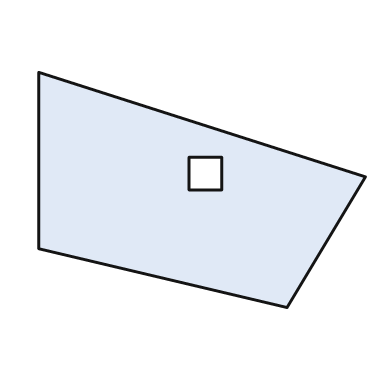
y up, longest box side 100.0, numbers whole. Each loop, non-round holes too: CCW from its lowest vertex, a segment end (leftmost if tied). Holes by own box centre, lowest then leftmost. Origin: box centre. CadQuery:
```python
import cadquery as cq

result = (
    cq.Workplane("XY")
    .moveTo(26.0, -36.0)
    .lineTo(50.0, 4.0)
    .lineTo(-50.0, 36.0)
    .lineTo(-50.0, -18.0)
    .close()
    .moveTo(-4.0, 0.0)
    .lineTo(6.0, 0.0)
    .lineTo(6.0, 10.0)
    .lineTo(-4.0, 10.0)
    .close()
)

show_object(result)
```